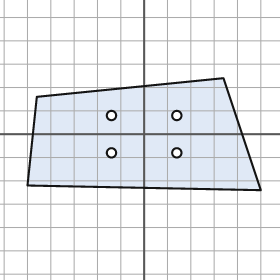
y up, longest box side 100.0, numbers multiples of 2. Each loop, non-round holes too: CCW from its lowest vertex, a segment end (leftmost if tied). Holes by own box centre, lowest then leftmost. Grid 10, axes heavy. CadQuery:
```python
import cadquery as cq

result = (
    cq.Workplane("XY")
    .moveTo(50.0, -24.0)
    .lineTo(34.0, 24.0)
    .lineTo(-46.0, 16.0)
    .lineTo(-50.0, -22.0)
    .close()
    .moveTo(-14.0, -8.0)
    .circle(2.0)
    .moveTo(14.0, -8.0)
    .circle(2.0)
    .moveTo(-14.0, 8.0)
    .circle(2.0)
    .moveTo(14.0, 8.0)
    .circle(2.0)
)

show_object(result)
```